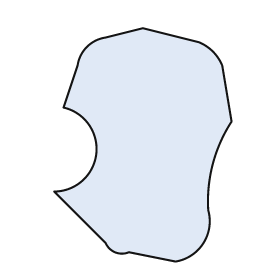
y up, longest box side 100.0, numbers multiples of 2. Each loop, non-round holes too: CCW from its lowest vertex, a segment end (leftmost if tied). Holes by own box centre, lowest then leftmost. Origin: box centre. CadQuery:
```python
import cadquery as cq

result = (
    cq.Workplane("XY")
    .moveTo(14.0, -50.0)
    .threePointArc((26.0, -42.0), (28.0, -28.0))
    .threePointArc((30.0, -8.0), (38.0, 10.0))
    .lineTo(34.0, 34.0)
    .threePointArc((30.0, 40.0), (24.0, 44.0))
    .lineTo(0.0, 50.0)
    .lineTo(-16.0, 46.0)
    .threePointArc((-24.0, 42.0), (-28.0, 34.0))
    .lineTo(-34.0, 16.0)
    .threePointArc((-20.0, -4.0), (-38.0, -20.0))
    .lineTo(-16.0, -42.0)
    .threePointArc((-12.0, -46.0), (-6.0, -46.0))
    .close()
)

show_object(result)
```